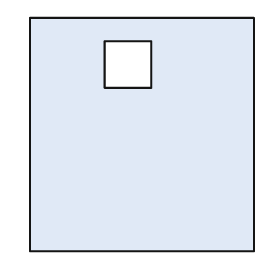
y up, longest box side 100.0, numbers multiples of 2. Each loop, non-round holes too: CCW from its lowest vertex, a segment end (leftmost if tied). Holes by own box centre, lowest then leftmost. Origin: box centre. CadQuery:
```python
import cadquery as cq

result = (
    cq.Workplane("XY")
    .moveTo(-48.0, -50.0)
    .lineTo(48.0, -50.0)
    .lineTo(48.0, 50.0)
    .lineTo(-48.0, 50.0)
    .close()
    .moveTo(-16.0, 20.0)
    .lineTo(4.0, 20.0)
    .lineTo(4.0, 40.0)
    .lineTo(-16.0, 40.0)
    .close()
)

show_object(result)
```